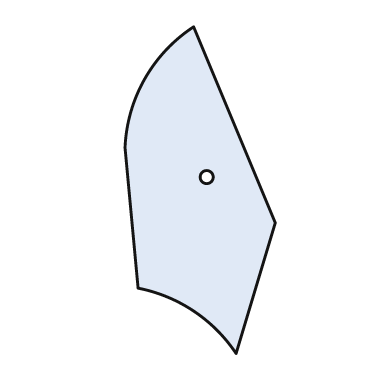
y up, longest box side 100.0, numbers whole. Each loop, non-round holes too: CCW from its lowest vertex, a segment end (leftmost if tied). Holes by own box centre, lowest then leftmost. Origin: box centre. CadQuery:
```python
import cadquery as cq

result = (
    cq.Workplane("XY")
    .moveTo(11.0, -50.0)
    .lineTo(23.0, -10.0)
    .lineTo(-2.0, 50.0)
    .threePointArc((-17.0, 34.0), (-23.0, 13.0))
    .lineTo(-19.0, -30.0)
    .threePointArc((-2.0, -37.0), (11.0, -50.0))
    .close()
    .moveTo(2.0, 4.0)
    .circle(2.0)
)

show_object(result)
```